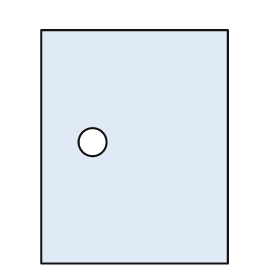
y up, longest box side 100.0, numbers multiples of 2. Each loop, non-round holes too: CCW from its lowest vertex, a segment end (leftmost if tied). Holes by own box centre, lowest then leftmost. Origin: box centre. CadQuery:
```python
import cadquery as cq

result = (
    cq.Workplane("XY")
    .moveTo(-40.0, -50.0)
    .lineTo(40.0, -50.0)
    .lineTo(40.0, 50.0)
    .lineTo(-40.0, 50.0)
    .close()
    .moveTo(-18.0, 2.0)
    .circle(6.0)
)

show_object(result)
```